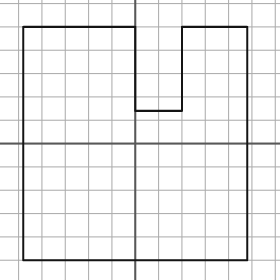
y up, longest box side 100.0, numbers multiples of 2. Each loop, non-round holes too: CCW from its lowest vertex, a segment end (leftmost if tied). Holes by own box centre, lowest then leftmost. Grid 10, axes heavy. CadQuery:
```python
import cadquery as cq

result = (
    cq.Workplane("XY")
    .moveTo(-48.0, -50.0)
    .lineTo(48.0, -50.0)
    .lineTo(48.0, 50.0)
    .lineTo(20.0, 50.0)
    .lineTo(20.0, 14.0)
    .lineTo(0.0, 14.0)
    .lineTo(0.0, 50.0)
    .lineTo(-48.0, 50.0)
    .close()
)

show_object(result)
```